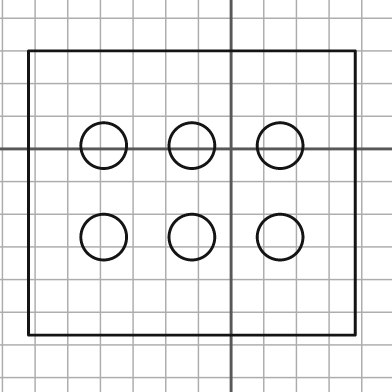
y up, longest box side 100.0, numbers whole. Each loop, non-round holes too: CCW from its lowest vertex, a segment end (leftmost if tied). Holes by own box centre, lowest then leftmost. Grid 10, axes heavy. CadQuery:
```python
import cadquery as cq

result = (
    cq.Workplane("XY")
    .moveTo(-62.0, -57.0)
    .lineTo(38.0, -57.0)
    .lineTo(38.0, 30.0)
    .lineTo(-62.0, 30.0)
    .close()
    .moveTo(-39.0, -27.0)
    .circle(7.0)
    .moveTo(-12.0, -27.0)
    .circle(7.0)
    .moveTo(15.0, -27.0)
    .circle(7.0)
    .moveTo(-39.0, 1.0)
    .circle(7.0)
    .moveTo(-12.0, 1.0)
    .circle(7.0)
    .moveTo(15.0, 1.0)
    .circle(7.0)
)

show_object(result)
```